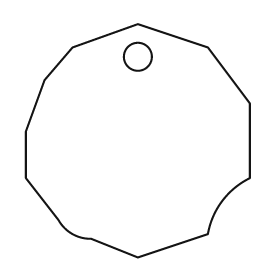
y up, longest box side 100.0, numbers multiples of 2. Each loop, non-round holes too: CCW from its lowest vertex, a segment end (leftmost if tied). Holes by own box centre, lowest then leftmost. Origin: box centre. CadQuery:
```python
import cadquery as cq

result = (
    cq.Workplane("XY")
    .moveTo(0.0, -50.0)
    .lineTo(30.0, -40.0)
    .threePointArc((36.0, -26.0), (48.0, -16.0))
    .lineTo(48.0, 16.0)
    .lineTo(30.0, 40.0)
    .lineTo(0.0, 50.0)
    .lineTo(-28.0, 40.0)
    .lineTo(-40.0, 26.0)
    .lineTo(-48.0, 4.0)
    .lineTo(-48.0, -16.0)
    .lineTo(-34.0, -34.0)
    .threePointArc((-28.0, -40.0), (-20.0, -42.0))
    .close()
    .moveTo(0.0, 36.0)
    .circle(6.0)
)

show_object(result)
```